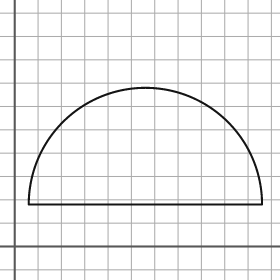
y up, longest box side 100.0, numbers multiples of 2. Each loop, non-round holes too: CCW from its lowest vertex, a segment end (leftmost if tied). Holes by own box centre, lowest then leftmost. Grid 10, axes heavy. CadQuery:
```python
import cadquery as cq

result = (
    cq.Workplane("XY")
    .moveTo(6.0, 18.0)
    .lineTo(106.0, 18.0)
    .threePointArc((56.0, 68.0), (6.0, 18.0))
    .close()
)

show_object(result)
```